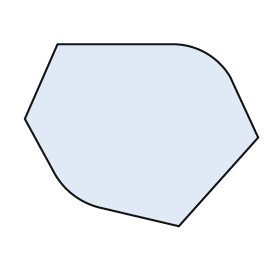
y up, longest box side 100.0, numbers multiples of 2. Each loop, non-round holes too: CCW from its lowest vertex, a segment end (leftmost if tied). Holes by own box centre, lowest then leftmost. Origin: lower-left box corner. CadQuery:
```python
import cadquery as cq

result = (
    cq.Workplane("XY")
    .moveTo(66.0, 0.0)
    .lineTo(100.0, 38.0)
    .lineTo(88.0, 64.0)
    .threePointArc((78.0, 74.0), (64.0, 78.0))
    .lineTo(14.0, 78.0)
    .lineTo(0.0, 46.0)
    .lineTo(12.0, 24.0)
    .threePointArc((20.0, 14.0), (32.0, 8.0))
    .close()
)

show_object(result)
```